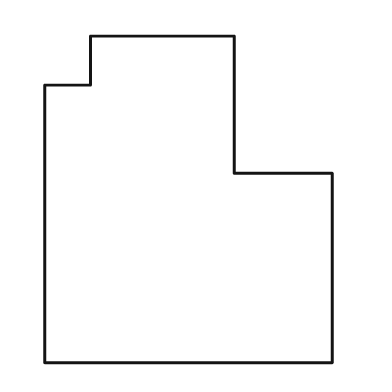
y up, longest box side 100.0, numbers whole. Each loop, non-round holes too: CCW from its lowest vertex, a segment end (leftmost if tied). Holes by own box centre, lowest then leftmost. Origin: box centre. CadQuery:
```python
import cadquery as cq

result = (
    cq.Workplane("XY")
    .moveTo(-44.0, -50.0)
    .lineTo(44.0, -50.0)
    .lineTo(44.0, 8.0)
    .lineTo(14.0, 8.0)
    .lineTo(14.0, 50.0)
    .lineTo(-30.0, 50.0)
    .lineTo(-30.0, 35.0)
    .lineTo(-44.0, 35.0)
    .close()
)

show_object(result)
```